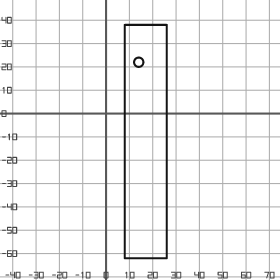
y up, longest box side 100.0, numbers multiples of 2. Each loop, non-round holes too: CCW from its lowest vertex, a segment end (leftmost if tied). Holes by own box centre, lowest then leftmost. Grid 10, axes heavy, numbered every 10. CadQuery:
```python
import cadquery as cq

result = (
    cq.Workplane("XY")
    .moveTo(8.0, -62.0)
    .lineTo(26.0, -62.0)
    .lineTo(26.0, 38.0)
    .lineTo(8.0, 38.0)
    .close()
    .moveTo(14.0, 22.0)
    .circle(2.0)
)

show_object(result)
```